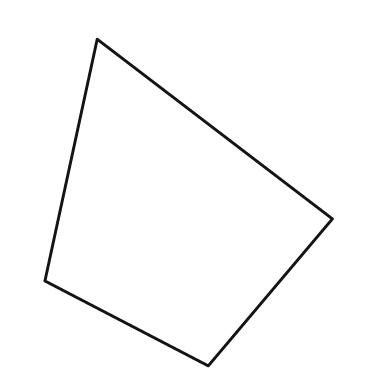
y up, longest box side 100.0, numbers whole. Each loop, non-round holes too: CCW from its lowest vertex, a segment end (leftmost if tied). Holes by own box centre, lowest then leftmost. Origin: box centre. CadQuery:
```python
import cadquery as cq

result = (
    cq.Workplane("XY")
    .moveTo(6.0, -50.0)
    .lineTo(44.0, -5.0)
    .lineTo(-28.0, 50.0)
    .lineTo(-44.0, -24.0)
    .close()
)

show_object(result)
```